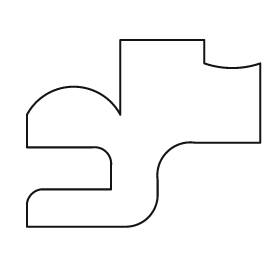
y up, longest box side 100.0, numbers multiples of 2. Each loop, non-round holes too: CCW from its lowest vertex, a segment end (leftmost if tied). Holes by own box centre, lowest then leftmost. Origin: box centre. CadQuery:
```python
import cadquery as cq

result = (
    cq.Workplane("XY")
    .moveTo(-50.0, -40.0)
    .lineTo(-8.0, -40.0)
    .threePointArc((2.0, -36.0), (6.0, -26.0))
    .lineTo(6.0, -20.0)
    .threePointArc((10.0, -8.0), (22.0, -4.0))
    .lineTo(50.0, -4.0)
    .lineTo(50.0, 30.0)
    .threePointArc((38.0, 28.0), (26.0, 30.0))
    .lineTo(26.0, 40.0)
    .lineTo(-10.0, 40.0)
    .lineTo(-10.0, 8.0)
    .threePointArc((-30.0, 20.0), (-50.0, 8.0))
    .lineTo(-50.0, -6.0)
    .lineTo(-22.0, -6.0)
    .threePointArc((-16.0, -8.0), (-14.0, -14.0))
    .lineTo(-14.0, -24.0)
    .lineTo(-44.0, -24.0)
    .threePointArc((-48.0, -26.0), (-50.0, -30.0))
    .close()
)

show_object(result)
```